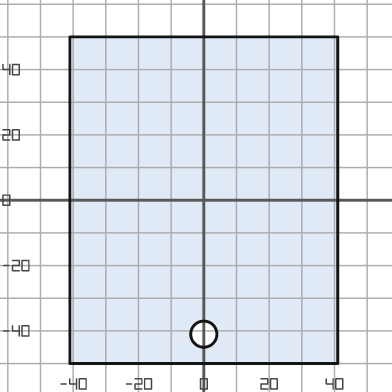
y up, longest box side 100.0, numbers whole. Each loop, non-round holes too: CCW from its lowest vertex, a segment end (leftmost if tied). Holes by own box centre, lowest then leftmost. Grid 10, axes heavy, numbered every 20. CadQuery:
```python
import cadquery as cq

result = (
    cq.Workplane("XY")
    .moveTo(-41.0, -50.0)
    .lineTo(41.0, -50.0)
    .lineTo(41.0, 50.0)
    .lineTo(-41.0, 50.0)
    .close()
    .moveTo(0.0, -41.0)
    .circle(4.0)
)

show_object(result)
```